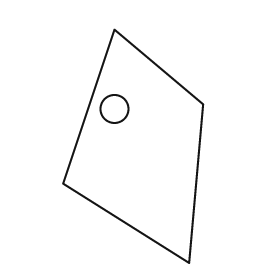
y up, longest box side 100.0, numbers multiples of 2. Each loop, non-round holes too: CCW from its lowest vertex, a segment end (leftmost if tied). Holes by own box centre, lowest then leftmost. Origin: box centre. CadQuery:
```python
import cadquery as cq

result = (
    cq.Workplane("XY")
    .moveTo(24.0, -50.0)
    .lineTo(30.0, 18.0)
    .lineTo(-8.0, 50.0)
    .lineTo(-30.0, -16.0)
    .close()
    .moveTo(-8.0, 16.0)
    .circle(6.0)
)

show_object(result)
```